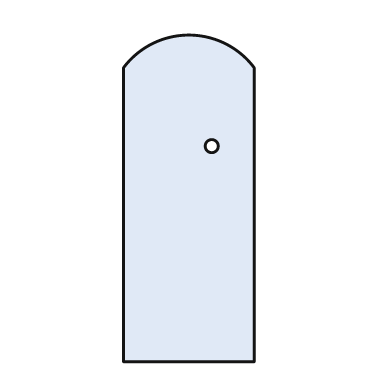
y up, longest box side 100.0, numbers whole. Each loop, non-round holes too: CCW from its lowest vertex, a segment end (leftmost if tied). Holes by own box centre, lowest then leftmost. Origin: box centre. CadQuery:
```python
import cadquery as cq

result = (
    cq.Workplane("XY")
    .moveTo(-20.0, -50.0)
    .lineTo(20.0, -50.0)
    .lineTo(20.0, 40.0)
    .threePointArc((0.0, 50.0), (-20.0, 40.0))
    .close()
    .moveTo(7.0, 16.0)
    .circle(2.0)
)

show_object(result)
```